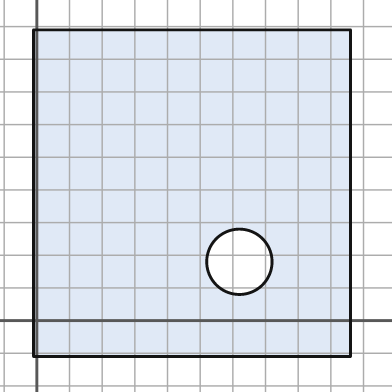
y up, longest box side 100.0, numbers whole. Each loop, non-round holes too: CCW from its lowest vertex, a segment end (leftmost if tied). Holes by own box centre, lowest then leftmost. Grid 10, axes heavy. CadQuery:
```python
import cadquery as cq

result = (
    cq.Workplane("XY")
    .moveTo(-1.0, -11.0)
    .lineTo(96.0, -11.0)
    .lineTo(96.0, 89.0)
    .lineTo(-1.0, 89.0)
    .close()
    .moveTo(62.0, 18.0)
    .circle(10.0)
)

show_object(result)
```